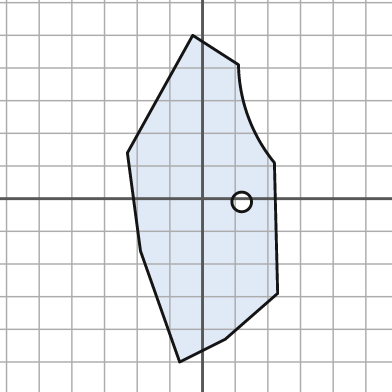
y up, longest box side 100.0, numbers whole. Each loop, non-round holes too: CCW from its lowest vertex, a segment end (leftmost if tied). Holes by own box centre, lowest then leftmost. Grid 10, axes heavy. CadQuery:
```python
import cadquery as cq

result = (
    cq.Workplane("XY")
    .moveTo(-7.0, -50.0)
    .lineTo(7.0, -43.0)
    .lineTo(23.0, -29.0)
    .lineTo(22.0, 11.0)
    .threePointArc((14.0, 25.0), (11.0, 41.0))
    .lineTo(-3.0, 50.0)
    .lineTo(-23.0, 14.0)
    .lineTo(-19.0, -16.0)
    .close()
    .moveTo(12.0, -1.0)
    .circle(3.0)
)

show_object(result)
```